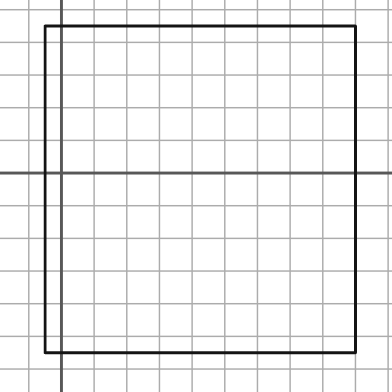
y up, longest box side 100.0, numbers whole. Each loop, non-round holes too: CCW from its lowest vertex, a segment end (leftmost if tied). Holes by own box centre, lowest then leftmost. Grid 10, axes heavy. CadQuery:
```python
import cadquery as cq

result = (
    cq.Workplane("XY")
    .moveTo(-5.0, -55.0)
    .lineTo(90.0, -55.0)
    .lineTo(90.0, 45.0)
    .lineTo(-5.0, 45.0)
    .close()
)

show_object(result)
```